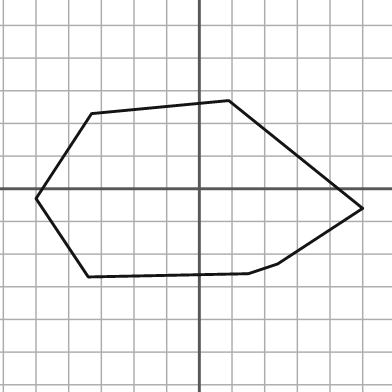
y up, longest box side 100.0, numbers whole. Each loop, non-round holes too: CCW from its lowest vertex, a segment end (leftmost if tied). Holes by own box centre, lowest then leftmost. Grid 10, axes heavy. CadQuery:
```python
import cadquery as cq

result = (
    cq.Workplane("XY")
    .moveTo(-34.0, -27.0)
    .lineTo(15.0, -26.0)
    .lineTo(24.0, -23.0)
    .lineTo(50.0, -6.0)
    .lineTo(9.0, 27.0)
    .lineTo(-33.0, 23.0)
    .lineTo(-50.0, -3.0)
    .close()
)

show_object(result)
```